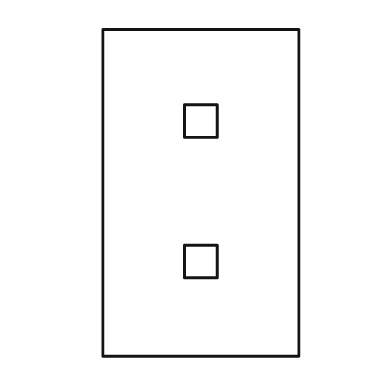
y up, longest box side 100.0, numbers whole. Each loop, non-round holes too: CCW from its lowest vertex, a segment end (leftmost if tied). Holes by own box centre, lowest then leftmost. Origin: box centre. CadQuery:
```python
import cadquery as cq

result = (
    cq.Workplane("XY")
    .moveTo(-30.0, -50.0)
    .lineTo(30.0, -50.0)
    .lineTo(30.0, 50.0)
    .lineTo(-30.0, 50.0)
    .close()
    .moveTo(-5.0, -26.0)
    .lineTo(5.0, -26.0)
    .lineTo(5.0, -16.0)
    .lineTo(-5.0, -16.0)
    .close()
    .moveTo(-5.0, 17.0)
    .lineTo(5.0, 17.0)
    .lineTo(5.0, 27.0)
    .lineTo(-5.0, 27.0)
    .close()
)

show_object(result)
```